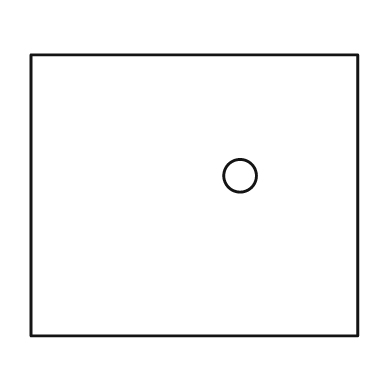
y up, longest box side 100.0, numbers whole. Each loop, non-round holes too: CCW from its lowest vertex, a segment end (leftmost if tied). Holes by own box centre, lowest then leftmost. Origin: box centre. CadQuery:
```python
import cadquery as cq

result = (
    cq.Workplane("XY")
    .moveTo(-50.0, -43.0)
    .lineTo(50.0, -43.0)
    .lineTo(50.0, 43.0)
    .lineTo(-50.0, 43.0)
    .close()
    .moveTo(14.0, 6.0)
    .circle(5.0)
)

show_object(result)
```